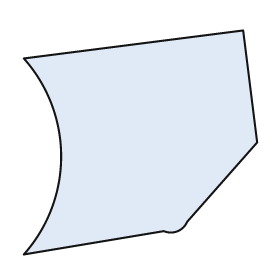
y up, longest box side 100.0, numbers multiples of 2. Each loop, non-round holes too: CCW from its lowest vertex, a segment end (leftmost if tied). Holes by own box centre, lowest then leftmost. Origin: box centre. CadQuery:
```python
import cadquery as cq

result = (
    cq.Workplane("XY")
    .moveTo(-50.0, -48.0)
    .lineTo(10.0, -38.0)
    .threePointArc((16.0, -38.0), (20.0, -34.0))
    .lineTo(50.0, 0.0)
    .lineTo(44.0, 48.0)
    .lineTo(-50.0, 36.0)
    .threePointArc((-34.0, -6.0), (-50.0, -48.0))
    .close()
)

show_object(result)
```